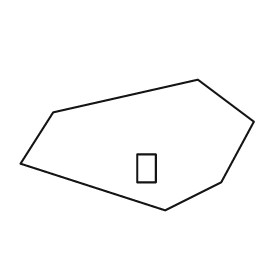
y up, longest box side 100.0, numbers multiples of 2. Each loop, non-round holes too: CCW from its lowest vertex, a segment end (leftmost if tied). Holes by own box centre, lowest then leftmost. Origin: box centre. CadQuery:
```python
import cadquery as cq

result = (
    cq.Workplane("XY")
    .moveTo(12.0, -28.0)
    .lineTo(36.0, -16.0)
    .lineTo(50.0, 10.0)
    .lineTo(26.0, 28.0)
    .lineTo(-36.0, 14.0)
    .lineTo(-50.0, -8.0)
    .close()
    .moveTo(0.0, -16.0)
    .lineTo(8.0, -16.0)
    .lineTo(8.0, -4.0)
    .lineTo(0.0, -4.0)
    .close()
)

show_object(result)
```